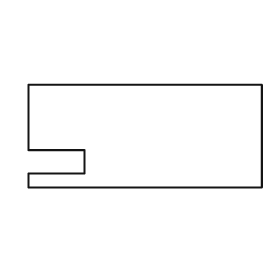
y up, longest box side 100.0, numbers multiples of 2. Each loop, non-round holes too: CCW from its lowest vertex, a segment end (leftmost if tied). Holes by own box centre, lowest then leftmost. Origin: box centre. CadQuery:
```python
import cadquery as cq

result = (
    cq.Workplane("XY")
    .moveTo(-50.0, -22.0)
    .lineTo(50.0, -22.0)
    .lineTo(50.0, 22.0)
    .lineTo(-50.0, 22.0)
    .lineTo(-50.0, -6.0)
    .lineTo(-26.0, -6.0)
    .lineTo(-26.0, -16.0)
    .lineTo(-50.0, -16.0)
    .close()
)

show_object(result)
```